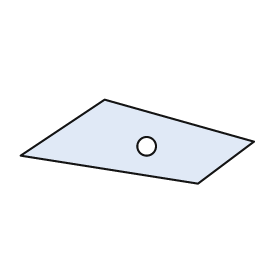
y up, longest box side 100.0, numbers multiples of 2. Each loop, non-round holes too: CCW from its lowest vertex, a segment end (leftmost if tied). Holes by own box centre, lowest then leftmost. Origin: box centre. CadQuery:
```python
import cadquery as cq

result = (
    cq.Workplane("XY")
    .moveTo(26.0, -18.0)
    .lineTo(50.0, 0.0)
    .lineTo(-14.0, 18.0)
    .lineTo(-50.0, -6.0)
    .close()
    .moveTo(4.0, -2.0)
    .circle(4.0)
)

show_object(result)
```